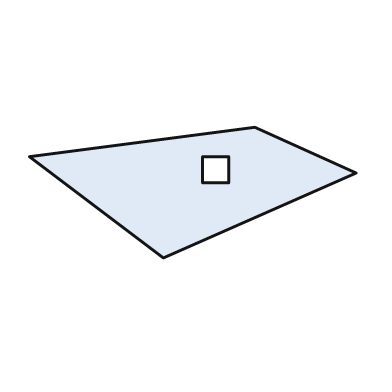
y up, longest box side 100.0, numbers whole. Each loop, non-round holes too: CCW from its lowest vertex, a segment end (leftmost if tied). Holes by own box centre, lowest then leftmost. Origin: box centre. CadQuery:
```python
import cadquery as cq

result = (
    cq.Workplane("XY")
    .moveTo(-9.0, -20.0)
    .lineTo(50.0, 6.0)
    .lineTo(19.0, 20.0)
    .lineTo(-50.0, 11.0)
    .close()
    .moveTo(3.0, 3.0)
    .lineTo(11.0, 3.0)
    .lineTo(11.0, 11.0)
    .lineTo(3.0, 11.0)
    .close()
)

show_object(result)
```